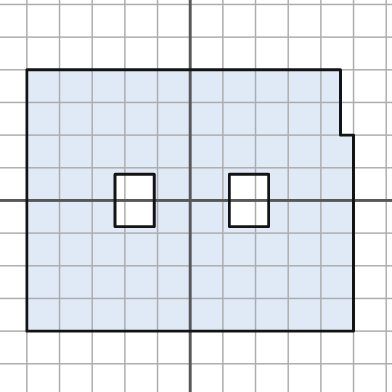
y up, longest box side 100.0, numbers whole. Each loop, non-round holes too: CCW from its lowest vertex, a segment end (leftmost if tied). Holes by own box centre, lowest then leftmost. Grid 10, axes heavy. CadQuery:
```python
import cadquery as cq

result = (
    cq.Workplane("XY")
    .moveTo(-50.0, -40.0)
    .lineTo(50.0, -40.0)
    .lineTo(50.0, 20.0)
    .lineTo(46.0, 20.0)
    .lineTo(46.0, 40.0)
    .lineTo(-50.0, 40.0)
    .close()
    .moveTo(-23.0, -8.0)
    .lineTo(-11.0, -8.0)
    .lineTo(-11.0, 8.0)
    .lineTo(-23.0, 8.0)
    .close()
    .moveTo(12.0, -8.0)
    .lineTo(24.0, -8.0)
    .lineTo(24.0, 8.0)
    .lineTo(12.0, 8.0)
    .close()
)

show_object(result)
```